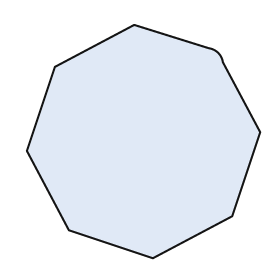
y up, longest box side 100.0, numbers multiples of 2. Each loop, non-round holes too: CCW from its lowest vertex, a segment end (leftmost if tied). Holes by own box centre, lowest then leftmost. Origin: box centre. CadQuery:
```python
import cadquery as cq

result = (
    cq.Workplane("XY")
    .moveTo(4.0, -50.0)
    .lineTo(38.0, -32.0)
    .lineTo(50.0, 4.0)
    .lineTo(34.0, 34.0)
    .threePointArc((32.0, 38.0), (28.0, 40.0))
    .lineTo(-4.0, 50.0)
    .lineTo(-38.0, 32.0)
    .lineTo(-50.0, -4.0)
    .lineTo(-32.0, -38.0)
    .close()
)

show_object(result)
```